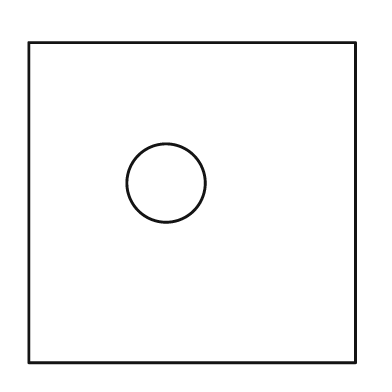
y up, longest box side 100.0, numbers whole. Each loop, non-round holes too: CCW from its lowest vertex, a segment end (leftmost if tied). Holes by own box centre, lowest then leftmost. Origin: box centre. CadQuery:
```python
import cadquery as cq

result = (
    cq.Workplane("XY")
    .moveTo(-50.0, -49.0)
    .lineTo(50.0, -49.0)
    .lineTo(50.0, 49.0)
    .lineTo(-50.0, 49.0)
    .close()
    .moveTo(-8.0, 6.0)
    .circle(12.0)
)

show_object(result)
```